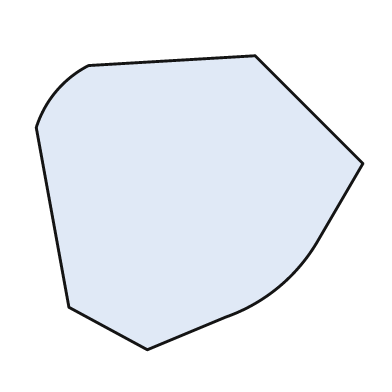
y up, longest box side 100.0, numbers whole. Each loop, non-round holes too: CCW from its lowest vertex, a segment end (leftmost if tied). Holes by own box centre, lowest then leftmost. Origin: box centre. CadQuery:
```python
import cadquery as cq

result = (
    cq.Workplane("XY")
    .moveTo(-16.0, -45.0)
    .lineTo(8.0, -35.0)
    .threePointArc((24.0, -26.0), (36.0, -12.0))
    .lineTo(50.0, 12.0)
    .lineTo(17.0, 45.0)
    .lineTo(-34.0, 42.0)
    .threePointArc((-44.0, 34.0), (-50.0, 23.0))
    .lineTo(-40.0, -32.0)
    .close()
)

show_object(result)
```